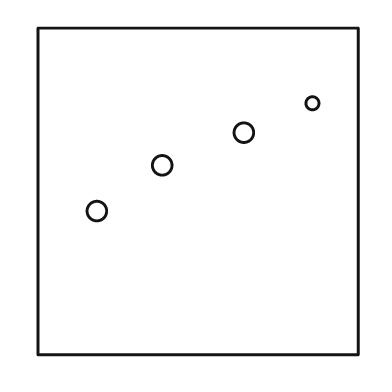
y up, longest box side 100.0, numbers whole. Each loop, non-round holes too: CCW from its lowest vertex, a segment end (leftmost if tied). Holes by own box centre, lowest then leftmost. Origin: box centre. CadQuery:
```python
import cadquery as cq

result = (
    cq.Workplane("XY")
    .moveTo(-49.0, -50.0)
    .lineTo(49.0, -50.0)
    .lineTo(49.0, 50.0)
    .lineTo(-49.0, 50.0)
    .close()
    .moveTo(-31.0, -6.0)
    .circle(3.0)
    .moveTo(-11.0, 8.0)
    .circle(3.0)
    .moveTo(14.0, 18.0)
    .circle(3.0)
    .moveTo(35.0, 27.0)
    .circle(2.0)
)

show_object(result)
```